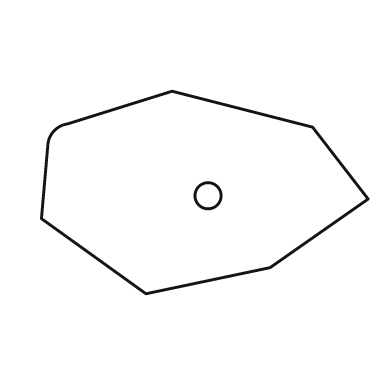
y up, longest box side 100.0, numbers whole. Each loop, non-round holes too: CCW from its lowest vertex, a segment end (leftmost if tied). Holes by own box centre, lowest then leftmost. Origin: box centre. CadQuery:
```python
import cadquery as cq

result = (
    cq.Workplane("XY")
    .moveTo(-18.0, -31.0)
    .lineTo(20.0, -23.0)
    .lineTo(50.0, -2.0)
    .lineTo(33.0, 20.0)
    .lineTo(-10.0, 31.0)
    .lineTo(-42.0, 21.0)
    .threePointArc((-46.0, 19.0), (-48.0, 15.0))
    .lineTo(-50.0, -8.0)
    .close()
    .moveTo(1.0, -1.0)
    .circle(4.0)
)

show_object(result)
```